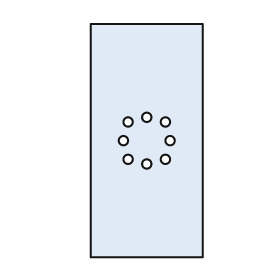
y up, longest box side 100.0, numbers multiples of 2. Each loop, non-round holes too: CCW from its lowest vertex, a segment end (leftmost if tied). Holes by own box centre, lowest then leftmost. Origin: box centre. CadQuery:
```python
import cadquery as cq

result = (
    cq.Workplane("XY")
    .moveTo(-24.0, -50.0)
    .lineTo(24.0, -50.0)
    .lineTo(24.0, 50.0)
    .lineTo(-24.0, 50.0)
    .close()
    .moveTo(0.0, -10.0)
    .circle(2.0)
    .moveTo(-8.0, -8.0)
    .circle(2.0)
    .moveTo(8.0, -8.0)
    .circle(2.0)
    .moveTo(-10.0, 0.0)
    .circle(2.0)
    .moveTo(10.0, 0.0)
    .circle(2.0)
    .moveTo(-8.0, 8.0)
    .circle(2.0)
    .moveTo(8.0, 8.0)
    .circle(2.0)
    .moveTo(0.0, 10.0)
    .circle(2.0)
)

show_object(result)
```